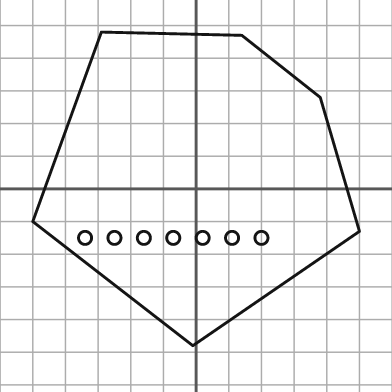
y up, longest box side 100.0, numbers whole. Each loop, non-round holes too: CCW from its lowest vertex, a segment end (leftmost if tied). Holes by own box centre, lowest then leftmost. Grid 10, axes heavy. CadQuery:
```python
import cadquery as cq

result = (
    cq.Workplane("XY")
    .moveTo(-1.0, -48.0)
    .lineTo(50.0, -13.0)
    .lineTo(38.0, 28.0)
    .lineTo(14.0, 47.0)
    .lineTo(-29.0, 48.0)
    .lineTo(-50.0, -10.0)
    .close()
    .moveTo(-34.0, -15.0)
    .circle(2.0)
    .moveTo(-25.0, -15.0)
    .circle(2.0)
    .moveTo(-16.0, -15.0)
    .circle(2.0)
    .moveTo(-7.0, -15.0)
    .circle(2.0)
    .moveTo(2.0, -15.0)
    .circle(2.0)
    .moveTo(11.0, -15.0)
    .circle(2.0)
    .moveTo(20.0, -15.0)
    .circle(2.0)
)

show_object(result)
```